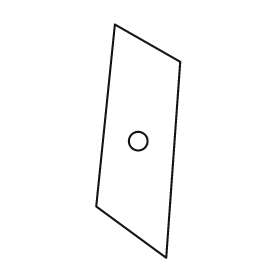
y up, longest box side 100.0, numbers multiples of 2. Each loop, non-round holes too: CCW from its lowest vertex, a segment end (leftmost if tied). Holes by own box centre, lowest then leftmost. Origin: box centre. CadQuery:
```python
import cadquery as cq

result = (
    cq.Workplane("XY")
    .moveTo(12.0, -50.0)
    .lineTo(18.0, 34.0)
    .lineTo(-10.0, 50.0)
    .lineTo(-18.0, -28.0)
    .close()
    .moveTo(0.0, 0.0)
    .circle(4.0)
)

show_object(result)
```